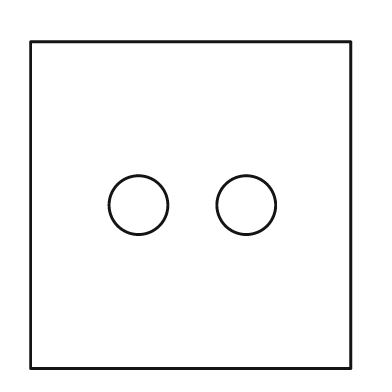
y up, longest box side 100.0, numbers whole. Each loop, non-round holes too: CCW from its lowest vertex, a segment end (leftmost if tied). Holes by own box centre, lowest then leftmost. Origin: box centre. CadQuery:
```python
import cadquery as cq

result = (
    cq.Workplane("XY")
    .moveTo(-49.0, -50.0)
    .lineTo(49.0, -50.0)
    .lineTo(49.0, 50.0)
    .lineTo(-49.0, 50.0)
    .close()
    .moveTo(-16.0, 0.0)
    .circle(9.0)
    .moveTo(17.0, 0.0)
    .circle(9.0)
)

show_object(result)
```